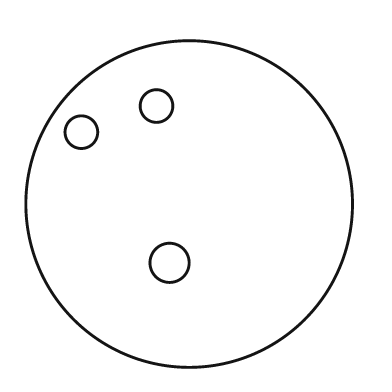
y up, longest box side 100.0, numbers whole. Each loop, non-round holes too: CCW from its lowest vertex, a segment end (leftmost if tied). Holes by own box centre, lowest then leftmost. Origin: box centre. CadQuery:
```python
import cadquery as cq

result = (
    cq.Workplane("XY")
    .moveTo(0.0, 0.0)
    .circle(50.0)
    .moveTo(-6.0, -18.0)
    .circle(6.0)
    .moveTo(-33.0, 22.0)
    .circle(5.0)
    .moveTo(-10.0, 30.0)
    .circle(5.0)
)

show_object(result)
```